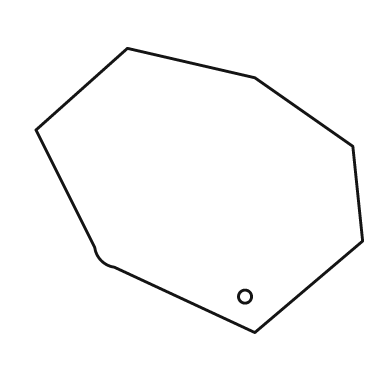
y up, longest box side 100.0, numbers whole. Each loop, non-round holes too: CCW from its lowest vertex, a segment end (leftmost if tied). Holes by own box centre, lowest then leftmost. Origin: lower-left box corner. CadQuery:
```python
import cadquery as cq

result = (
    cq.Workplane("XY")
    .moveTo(67.0, 0.0)
    .lineTo(100.0, 28.0)
    .lineTo(97.0, 57.0)
    .lineTo(67.0, 78.0)
    .lineTo(28.0, 87.0)
    .lineTo(0.0, 62.0)
    .lineTo(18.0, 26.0)
    .threePointArc((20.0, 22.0), (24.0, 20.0))
    .close()
    .moveTo(64.0, 11.0)
    .circle(2.0)
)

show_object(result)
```